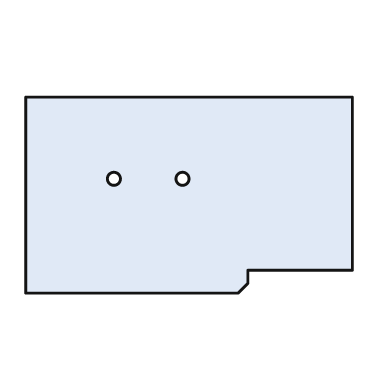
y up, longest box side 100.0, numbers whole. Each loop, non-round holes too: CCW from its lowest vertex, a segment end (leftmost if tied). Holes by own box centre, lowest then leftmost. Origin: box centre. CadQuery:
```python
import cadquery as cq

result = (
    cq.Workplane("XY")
    .moveTo(-50.0, -30.0)
    .lineTo(15.0, -30.0)
    .lineTo(18.0, -27.0)
    .lineTo(18.0, -23.0)
    .lineTo(50.0, -23.0)
    .lineTo(50.0, 30.0)
    .lineTo(-50.0, 30.0)
    .close()
    .moveTo(-23.0, 5.0)
    .circle(2.0)
    .moveTo(-2.0, 5.0)
    .circle(2.0)
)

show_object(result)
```